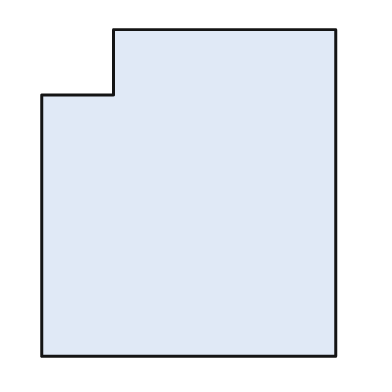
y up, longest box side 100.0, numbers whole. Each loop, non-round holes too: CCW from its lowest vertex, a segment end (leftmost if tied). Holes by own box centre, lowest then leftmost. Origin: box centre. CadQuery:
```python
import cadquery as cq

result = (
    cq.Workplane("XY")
    .moveTo(-45.0, -50.0)
    .lineTo(45.0, -50.0)
    .lineTo(45.0, 50.0)
    .lineTo(-23.0, 50.0)
    .lineTo(-23.0, 30.0)
    .lineTo(-45.0, 30.0)
    .close()
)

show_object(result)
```